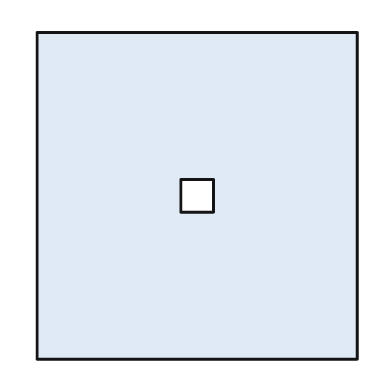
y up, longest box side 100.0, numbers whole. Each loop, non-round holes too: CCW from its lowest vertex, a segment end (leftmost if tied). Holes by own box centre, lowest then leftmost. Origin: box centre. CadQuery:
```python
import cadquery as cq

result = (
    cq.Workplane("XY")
    .moveTo(-49.0, -50.0)
    .lineTo(49.0, -50.0)
    .lineTo(49.0, 50.0)
    .lineTo(-49.0, 50.0)
    .close()
    .moveTo(-5.0, -5.0)
    .lineTo(5.0, -5.0)
    .lineTo(5.0, 5.0)
    .lineTo(-5.0, 5.0)
    .close()
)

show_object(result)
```